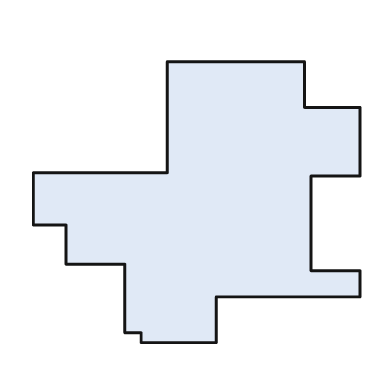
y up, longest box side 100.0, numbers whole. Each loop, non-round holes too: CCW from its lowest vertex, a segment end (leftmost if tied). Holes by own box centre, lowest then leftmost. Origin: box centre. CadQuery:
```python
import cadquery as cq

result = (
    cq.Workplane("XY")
    .moveTo(-17.0, -43.0)
    .lineTo(6.0, -43.0)
    .lineTo(6.0, -29.0)
    .lineTo(50.0, -29.0)
    .lineTo(50.0, -21.0)
    .lineTo(35.0, -21.0)
    .lineTo(35.0, 8.0)
    .lineTo(50.0, 8.0)
    .lineTo(50.0, 29.0)
    .lineTo(33.0, 29.0)
    .lineTo(33.0, 43.0)
    .lineTo(-9.0, 43.0)
    .lineTo(-9.0, 9.0)
    .lineTo(-50.0, 9.0)
    .lineTo(-50.0, -7.0)
    .lineTo(-40.0, -7.0)
    .lineTo(-40.0, -19.0)
    .lineTo(-22.0, -19.0)
    .lineTo(-22.0, -40.0)
    .lineTo(-17.0, -40.0)
    .close()
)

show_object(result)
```